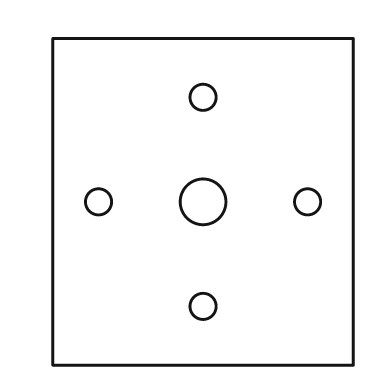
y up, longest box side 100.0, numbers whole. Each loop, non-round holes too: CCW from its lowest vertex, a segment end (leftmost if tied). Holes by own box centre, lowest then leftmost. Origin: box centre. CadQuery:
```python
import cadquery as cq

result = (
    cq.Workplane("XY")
    .moveTo(-46.0, -50.0)
    .lineTo(46.0, -50.0)
    .lineTo(46.0, 50.0)
    .lineTo(-46.0, 50.0)
    .close()
    .moveTo(0.0, -32.0)
    .circle(4.0)
    .moveTo(-32.0, 0.0)
    .circle(4.0)
    .moveTo(0.0, 0.0)
    .circle(7.0)
    .moveTo(32.0, 0.0)
    .circle(4.0)
    .moveTo(0.0, 32.0)
    .circle(4.0)
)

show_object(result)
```